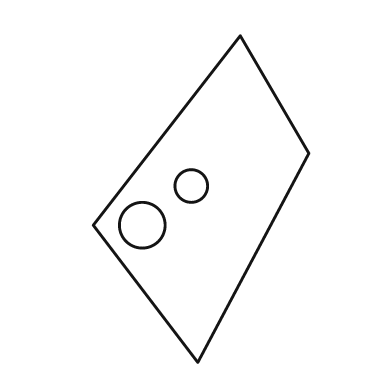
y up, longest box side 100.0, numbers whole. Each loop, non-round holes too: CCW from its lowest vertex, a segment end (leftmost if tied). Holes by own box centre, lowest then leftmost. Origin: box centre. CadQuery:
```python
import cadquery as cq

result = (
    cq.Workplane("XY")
    .moveTo(-1.0, -50.0)
    .lineTo(33.0, 14.0)
    .lineTo(12.0, 50.0)
    .lineTo(-33.0, -8.0)
    .close()
    .moveTo(-18.0, -8.0)
    .circle(7.0)
    .moveTo(-3.0, 4.0)
    .circle(5.0)
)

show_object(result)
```